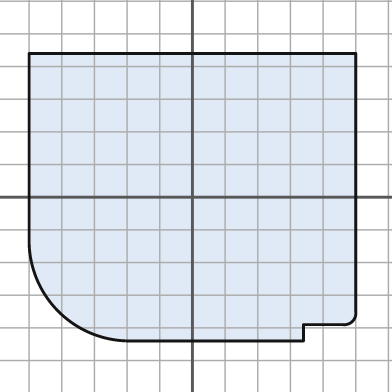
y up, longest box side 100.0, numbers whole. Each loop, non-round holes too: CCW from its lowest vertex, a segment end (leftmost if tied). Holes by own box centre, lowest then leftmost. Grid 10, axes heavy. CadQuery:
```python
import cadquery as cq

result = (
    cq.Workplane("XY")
    .moveTo(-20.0, -44.0)
    .lineTo(34.0, -44.0)
    .lineTo(34.0, -39.0)
    .lineTo(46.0, -39.0)
    .threePointArc((49.0, -38.0), (50.0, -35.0))
    .lineTo(50.0, 44.0)
    .lineTo(-50.0, 44.0)
    .lineTo(-50.0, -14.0)
    .threePointArc((-41.0, -35.0), (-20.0, -44.0))
    .close()
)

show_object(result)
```